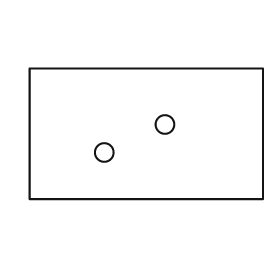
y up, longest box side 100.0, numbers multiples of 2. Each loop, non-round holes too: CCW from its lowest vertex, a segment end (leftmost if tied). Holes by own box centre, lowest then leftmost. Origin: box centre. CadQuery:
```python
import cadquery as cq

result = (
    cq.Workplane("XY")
    .moveTo(-50.0, -28.0)
    .lineTo(50.0, -28.0)
    .lineTo(50.0, 28.0)
    .lineTo(-50.0, 28.0)
    .close()
    .moveTo(-18.0, -8.0)
    .circle(4.0)
    .moveTo(8.0, 4.0)
    .circle(4.0)
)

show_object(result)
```